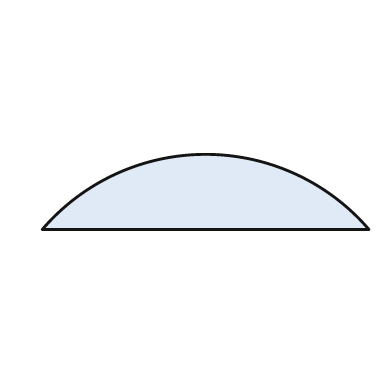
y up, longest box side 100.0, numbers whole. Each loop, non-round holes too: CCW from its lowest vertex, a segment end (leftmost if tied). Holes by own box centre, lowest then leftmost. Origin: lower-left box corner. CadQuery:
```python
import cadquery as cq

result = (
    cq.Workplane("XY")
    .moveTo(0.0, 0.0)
    .lineTo(100.0, 0.0)
    .threePointArc((50.0, 23.0), (0.0, 0.0))
    .close()
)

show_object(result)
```